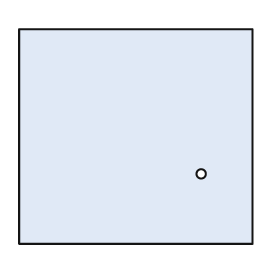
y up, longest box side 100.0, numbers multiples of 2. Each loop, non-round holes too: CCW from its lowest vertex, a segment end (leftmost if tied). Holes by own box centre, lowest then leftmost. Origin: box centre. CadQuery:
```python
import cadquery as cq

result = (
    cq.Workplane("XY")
    .moveTo(-50.0, -46.0)
    .lineTo(50.0, -46.0)
    .lineTo(50.0, 46.0)
    .lineTo(-50.0, 46.0)
    .close()
    .moveTo(28.0, -16.0)
    .circle(2.0)
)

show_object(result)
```